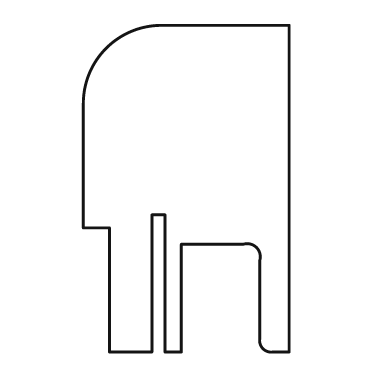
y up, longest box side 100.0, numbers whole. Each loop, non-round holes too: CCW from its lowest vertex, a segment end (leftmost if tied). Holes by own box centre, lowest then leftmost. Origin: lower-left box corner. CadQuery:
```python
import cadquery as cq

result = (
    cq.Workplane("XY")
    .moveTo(8.0, 0.0)
    .lineTo(21.0, 0.0)
    .lineTo(21.0, 42.0)
    .lineTo(25.0, 42.0)
    .lineTo(25.0, 0.0)
    .lineTo(30.0, 0.0)
    .lineTo(30.0, 33.0)
    .lineTo(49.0, 33.0)
    .threePointArc((53.0, 32.0), (54.0, 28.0))
    .lineTo(54.0, 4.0)
    .threePointArc((55.0, 1.0), (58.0, 0.0))
    .lineTo(63.0, 0.0)
    .lineTo(63.0, 100.0)
    .lineTo(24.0, 100.0)
    .threePointArc((7.0, 93.0), (0.0, 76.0))
    .lineTo(0.0, 38.0)
    .lineTo(8.0, 38.0)
    .close()
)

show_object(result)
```